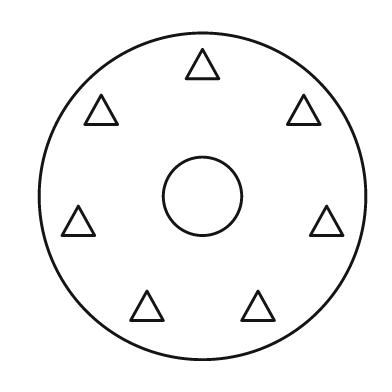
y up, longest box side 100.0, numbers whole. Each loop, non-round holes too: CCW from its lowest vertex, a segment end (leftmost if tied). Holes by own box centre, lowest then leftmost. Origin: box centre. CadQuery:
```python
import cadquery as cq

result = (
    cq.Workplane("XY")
    .moveTo(0.0, 0.0)
    .circle(50.0)
    .moveTo(-22.0, -38.0)
    .lineTo(-12.0, -38.0)
    .lineTo(-17.0, -29.0)
    .close()
    .moveTo(12.0, -38.0)
    .lineTo(22.0, -38.0)
    .lineTo(17.0, -29.0)
    .close()
    .moveTo(-43.0, -12.0)
    .lineTo(-33.0, -12.0)
    .lineTo(-38.0, -3.0)
    .close()
    .moveTo(33.0, -12.0)
    .lineTo(43.0, -12.0)
    .lineTo(38.0, -3.0)
    .close()
    .moveTo(0.0, 0.0)
    .circle(12.0)
    .moveTo(-36.0, 22.0)
    .lineTo(-26.0, 22.0)
    .lineTo(-31.0, 31.0)
    .close()
    .moveTo(26.0, 22.0)
    .lineTo(36.0, 22.0)
    .lineTo(31.0, 31.0)
    .close()
    .moveTo(-5.0, 36.0)
    .lineTo(5.0, 36.0)
    .lineTo(0.0, 45.0)
    .close()
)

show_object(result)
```